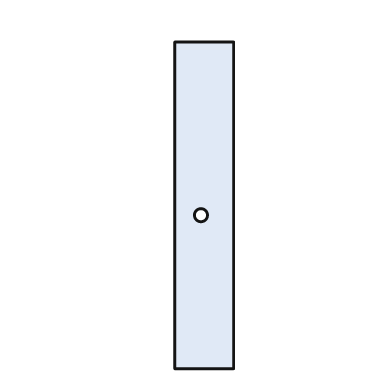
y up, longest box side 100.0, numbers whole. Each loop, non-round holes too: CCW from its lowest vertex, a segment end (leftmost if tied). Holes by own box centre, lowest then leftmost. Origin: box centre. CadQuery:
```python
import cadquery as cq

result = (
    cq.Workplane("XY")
    .moveTo(-9.0, -50.0)
    .lineTo(9.0, -50.0)
    .lineTo(9.0, 50.0)
    .lineTo(-9.0, 50.0)
    .close()
    .moveTo(-1.0, -3.0)
    .circle(2.0)
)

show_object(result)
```